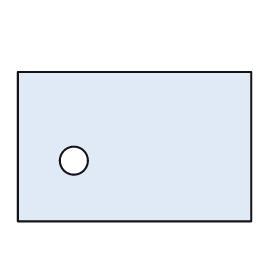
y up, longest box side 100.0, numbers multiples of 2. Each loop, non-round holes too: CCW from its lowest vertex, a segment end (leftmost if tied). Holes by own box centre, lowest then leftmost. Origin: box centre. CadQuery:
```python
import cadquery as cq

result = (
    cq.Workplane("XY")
    .moveTo(-50.0, -32.0)
    .lineTo(50.0, -32.0)
    .lineTo(50.0, 32.0)
    .lineTo(-50.0, 32.0)
    .close()
    .moveTo(-26.0, -6.0)
    .circle(6.0)
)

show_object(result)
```